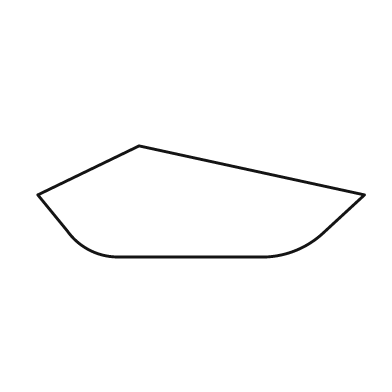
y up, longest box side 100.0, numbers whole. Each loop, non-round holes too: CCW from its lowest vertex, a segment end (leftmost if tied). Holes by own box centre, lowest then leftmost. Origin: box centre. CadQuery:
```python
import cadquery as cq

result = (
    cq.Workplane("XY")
    .moveTo(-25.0, -17.0)
    .lineTo(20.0, -17.0)
    .threePointArc((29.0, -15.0), (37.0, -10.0))
    .lineTo(50.0, 2.0)
    .lineTo(-19.0, 17.0)
    .lineTo(-50.0, 2.0)
    .lineTo(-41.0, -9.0)
    .threePointArc((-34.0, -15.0), (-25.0, -17.0))
    .close()
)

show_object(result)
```